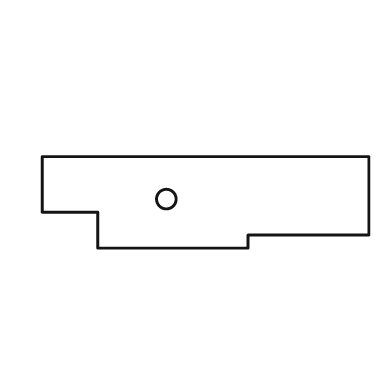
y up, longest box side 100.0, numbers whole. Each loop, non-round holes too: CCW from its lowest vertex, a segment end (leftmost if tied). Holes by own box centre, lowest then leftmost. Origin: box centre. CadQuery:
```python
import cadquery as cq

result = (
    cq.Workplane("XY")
    .moveTo(-33.0, -14.0)
    .lineTo(13.0, -14.0)
    .lineTo(13.0, -10.0)
    .lineTo(50.0, -10.0)
    .lineTo(50.0, 14.0)
    .lineTo(-50.0, 14.0)
    .lineTo(-50.0, -3.0)
    .lineTo(-33.0, -3.0)
    .close()
    .moveTo(-12.0, 1.0)
    .circle(3.0)
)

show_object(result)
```